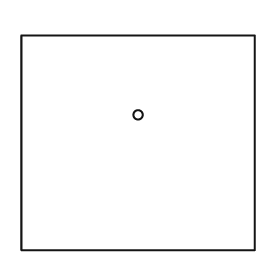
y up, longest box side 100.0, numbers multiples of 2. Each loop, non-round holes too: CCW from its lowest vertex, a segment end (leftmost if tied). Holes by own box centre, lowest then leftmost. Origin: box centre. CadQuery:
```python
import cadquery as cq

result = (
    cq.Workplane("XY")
    .moveTo(-50.0, -46.0)
    .lineTo(50.0, -46.0)
    .lineTo(50.0, 46.0)
    .lineTo(-50.0, 46.0)
    .close()
    .moveTo(0.0, 12.0)
    .circle(2.0)
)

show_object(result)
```